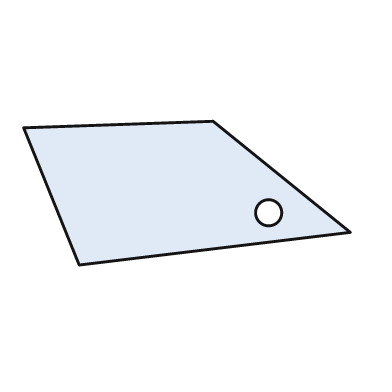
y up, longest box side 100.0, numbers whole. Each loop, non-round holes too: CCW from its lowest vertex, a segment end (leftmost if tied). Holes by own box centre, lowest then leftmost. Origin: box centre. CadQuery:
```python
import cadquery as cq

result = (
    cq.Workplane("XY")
    .moveTo(-33.0, -22.0)
    .lineTo(50.0, -12.0)
    .lineTo(8.0, 22.0)
    .lineTo(-50.0, 20.0)
    .close()
    .moveTo(25.0, -6.0)
    .circle(4.0)
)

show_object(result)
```